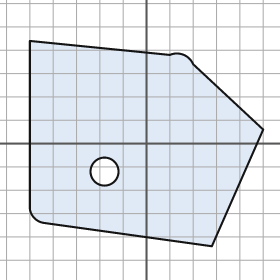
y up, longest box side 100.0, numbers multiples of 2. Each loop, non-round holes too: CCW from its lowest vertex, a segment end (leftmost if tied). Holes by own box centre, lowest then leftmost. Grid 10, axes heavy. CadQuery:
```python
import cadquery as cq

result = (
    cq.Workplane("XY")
    .moveTo(28.0, -44.0)
    .lineTo(50.0, 6.0)
    .lineTo(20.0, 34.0)
    .threePointArc((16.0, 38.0), (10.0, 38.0))
    .lineTo(-50.0, 44.0)
    .lineTo(-50.0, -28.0)
    .threePointArc((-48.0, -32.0), (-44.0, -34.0))
    .close()
    .moveTo(-18.0, -12.0)
    .circle(6.0)
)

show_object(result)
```